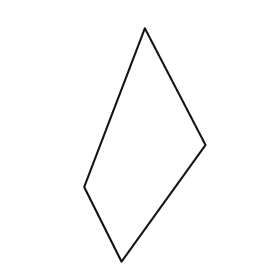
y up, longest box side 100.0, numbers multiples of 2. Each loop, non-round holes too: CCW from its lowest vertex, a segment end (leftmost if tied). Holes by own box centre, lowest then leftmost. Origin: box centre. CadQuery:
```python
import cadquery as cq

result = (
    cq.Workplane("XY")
    .moveTo(-10.0, -50.0)
    .lineTo(26.0, 0.0)
    .lineTo(0.0, 50.0)
    .lineTo(-26.0, -18.0)
    .close()
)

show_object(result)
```